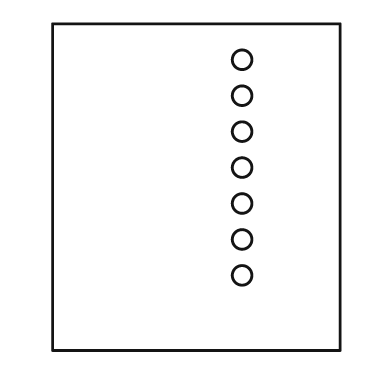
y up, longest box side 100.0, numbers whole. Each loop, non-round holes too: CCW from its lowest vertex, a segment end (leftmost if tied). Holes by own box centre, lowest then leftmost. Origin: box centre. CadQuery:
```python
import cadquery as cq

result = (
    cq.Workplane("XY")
    .moveTo(-44.0, -50.0)
    .lineTo(44.0, -50.0)
    .lineTo(44.0, 50.0)
    .lineTo(-44.0, 50.0)
    .close()
    .moveTo(14.0, -27.0)
    .circle(3.0)
    .moveTo(14.0, -16.0)
    .circle(3.0)
    .moveTo(14.0, -5.0)
    .circle(3.0)
    .moveTo(14.0, 6.0)
    .circle(3.0)
    .moveTo(14.0, 17.0)
    .circle(3.0)
    .moveTo(14.0, 28.0)
    .circle(3.0)
    .moveTo(14.0, 39.0)
    .circle(3.0)
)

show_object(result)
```